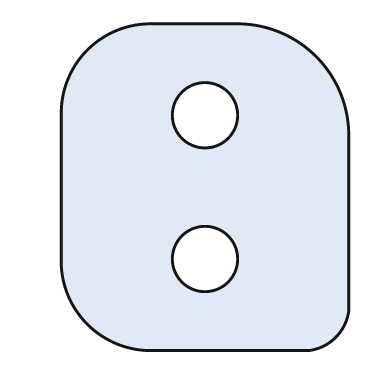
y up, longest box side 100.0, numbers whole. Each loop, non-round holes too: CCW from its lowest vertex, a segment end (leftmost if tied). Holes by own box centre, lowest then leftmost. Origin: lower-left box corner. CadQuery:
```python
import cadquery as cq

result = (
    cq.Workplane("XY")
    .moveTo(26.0, 0.0)
    .lineTo(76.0, 0.0)
    .threePointArc((84.0, 4.0), (88.0, 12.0))
    .lineTo(88.0, 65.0)
    .threePointArc((78.0, 90.0), (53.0, 100.0))
    .lineTo(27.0, 100.0)
    .threePointArc((8.0, 92.0), (0.0, 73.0))
    .lineTo(0.0, 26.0)
    .threePointArc((8.0, 8.0), (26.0, 0.0))
    .close()
    .moveTo(44.0, 28.0)
    .circle(10.0)
    .moveTo(44.0, 72.0)
    .circle(10.0)
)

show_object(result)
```